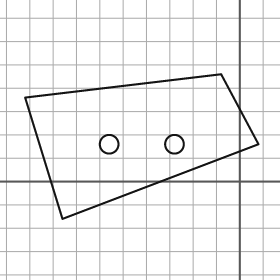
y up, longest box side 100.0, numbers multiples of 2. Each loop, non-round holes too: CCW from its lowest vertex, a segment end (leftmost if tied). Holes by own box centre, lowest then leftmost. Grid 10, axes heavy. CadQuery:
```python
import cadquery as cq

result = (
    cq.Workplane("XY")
    .moveTo(-76.0, -16.0)
    .lineTo(8.0, 16.0)
    .lineTo(-8.0, 46.0)
    .lineTo(-92.0, 36.0)
    .close()
    .moveTo(-56.0, 16.0)
    .circle(4.0)
    .moveTo(-28.0, 16.0)
    .circle(4.0)
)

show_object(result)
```